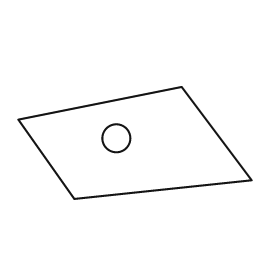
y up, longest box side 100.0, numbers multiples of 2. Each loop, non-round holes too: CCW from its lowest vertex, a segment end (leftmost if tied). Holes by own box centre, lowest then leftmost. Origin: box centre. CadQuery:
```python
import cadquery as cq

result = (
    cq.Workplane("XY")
    .moveTo(-26.0, -24.0)
    .lineTo(50.0, -16.0)
    .lineTo(20.0, 24.0)
    .lineTo(-50.0, 10.0)
    .close()
    .moveTo(-8.0, 2.0)
    .circle(6.0)
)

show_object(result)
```